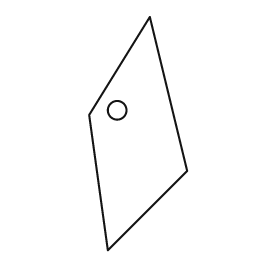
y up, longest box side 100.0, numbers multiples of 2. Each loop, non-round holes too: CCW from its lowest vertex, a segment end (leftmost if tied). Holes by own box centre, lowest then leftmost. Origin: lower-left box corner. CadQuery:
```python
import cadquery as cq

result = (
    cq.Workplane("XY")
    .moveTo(8.0, 0.0)
    .lineTo(42.0, 34.0)
    .lineTo(26.0, 100.0)
    .lineTo(0.0, 58.0)
    .close()
    .moveTo(12.0, 60.0)
    .circle(4.0)
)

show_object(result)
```